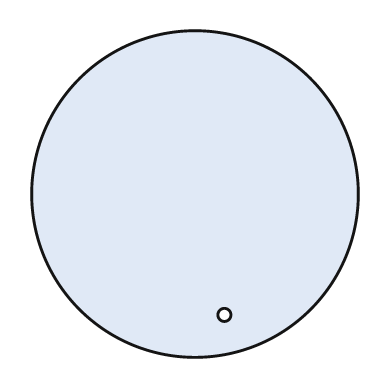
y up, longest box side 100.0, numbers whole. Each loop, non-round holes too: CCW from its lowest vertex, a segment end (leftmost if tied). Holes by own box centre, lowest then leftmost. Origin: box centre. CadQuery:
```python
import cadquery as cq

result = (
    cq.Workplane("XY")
    .moveTo(0.0, 0.0)
    .circle(50.0)
    .moveTo(9.0, -37.0)
    .circle(2.0)
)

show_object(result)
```